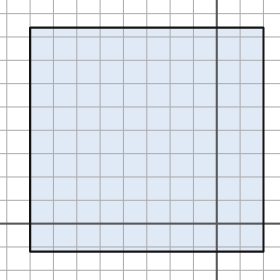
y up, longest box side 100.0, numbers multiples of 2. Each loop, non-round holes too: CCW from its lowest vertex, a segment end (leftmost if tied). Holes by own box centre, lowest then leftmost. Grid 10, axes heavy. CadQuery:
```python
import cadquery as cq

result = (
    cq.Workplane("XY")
    .moveTo(-80.0, -12.0)
    .lineTo(20.0, -12.0)
    .lineTo(20.0, 84.0)
    .lineTo(-80.0, 84.0)
    .close()
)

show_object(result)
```